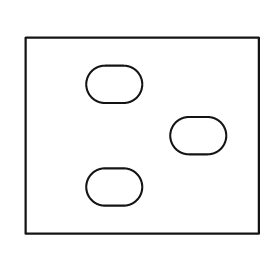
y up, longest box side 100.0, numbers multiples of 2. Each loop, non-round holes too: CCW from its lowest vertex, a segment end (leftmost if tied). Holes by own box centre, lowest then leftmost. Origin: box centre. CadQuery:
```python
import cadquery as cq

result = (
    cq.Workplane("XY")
    .moveTo(-50.0, -42.0)
    .lineTo(50.0, -42.0)
    .lineTo(50.0, 42.0)
    .lineTo(-50.0, 42.0)
    .close()
    .moveTo(-16.0, -30.0)
    .lineTo(-8.0, -30.0)
    .threePointArc((0.0, -22.0), (-8.0, -14.0))
    .lineTo(-16.0, -14.0)
    .threePointArc((-24.0, -22.0), (-16.0, -30.0))
    .close()
    .moveTo(20.0, -8.0)
    .lineTo(28.0, -8.0)
    .threePointArc((36.0, 0.0), (28.0, 8.0))
    .lineTo(20.0, 8.0)
    .threePointArc((12.0, 0.0), (20.0, -8.0))
    .close()
    .moveTo(-16.0, 14.0)
    .lineTo(-8.0, 14.0)
    .threePointArc((0.0, 22.0), (-8.0, 30.0))
    .lineTo(-16.0, 30.0)
    .threePointArc((-24.0, 22.0), (-16.0, 14.0))
    .close()
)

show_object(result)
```